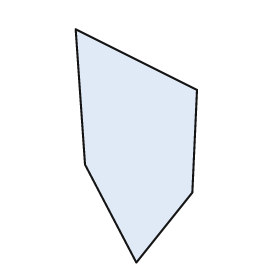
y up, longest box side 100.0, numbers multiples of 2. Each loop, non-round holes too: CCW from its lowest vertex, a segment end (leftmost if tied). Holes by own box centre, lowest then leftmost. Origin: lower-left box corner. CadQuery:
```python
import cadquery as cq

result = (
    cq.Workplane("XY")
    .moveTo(26.0, 0.0)
    .lineTo(50.0, 30.0)
    .lineTo(52.0, 74.0)
    .lineTo(0.0, 100.0)
    .lineTo(4.0, 42.0)
    .close()
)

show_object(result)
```